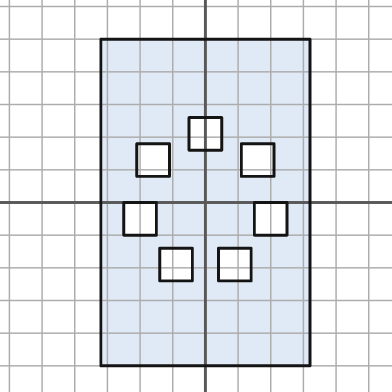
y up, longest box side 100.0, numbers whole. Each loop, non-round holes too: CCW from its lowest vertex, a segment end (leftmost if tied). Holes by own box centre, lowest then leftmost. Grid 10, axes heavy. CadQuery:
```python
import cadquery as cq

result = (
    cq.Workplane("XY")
    .moveTo(-32.0, -50.0)
    .lineTo(32.0, -50.0)
    .lineTo(32.0, 50.0)
    .lineTo(-32.0, 50.0)
    .close()
    .moveTo(-14.0, -24.0)
    .lineTo(-4.0, -24.0)
    .lineTo(-4.0, -14.0)
    .lineTo(-14.0, -14.0)
    .close()
    .moveTo(4.0, -24.0)
    .lineTo(14.0, -24.0)
    .lineTo(14.0, -14.0)
    .lineTo(4.0, -14.0)
    .close()
    .moveTo(-25.0, -10.0)
    .lineTo(-15.0, -10.0)
    .lineTo(-15.0, 0.0)
    .lineTo(-25.0, 0.0)
    .close()
    .moveTo(15.0, -10.0)
    .lineTo(25.0, -10.0)
    .lineTo(25.0, 0.0)
    .lineTo(15.0, 0.0)
    .close()
    .moveTo(-21.0, 8.0)
    .lineTo(-11.0, 8.0)
    .lineTo(-11.0, 18.0)
    .lineTo(-21.0, 18.0)
    .close()
    .moveTo(11.0, 8.0)
    .lineTo(21.0, 8.0)
    .lineTo(21.0, 18.0)
    .lineTo(11.0, 18.0)
    .close()
    .moveTo(-5.0, 16.0)
    .lineTo(5.0, 16.0)
    .lineTo(5.0, 26.0)
    .lineTo(-5.0, 26.0)
    .close()
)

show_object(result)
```